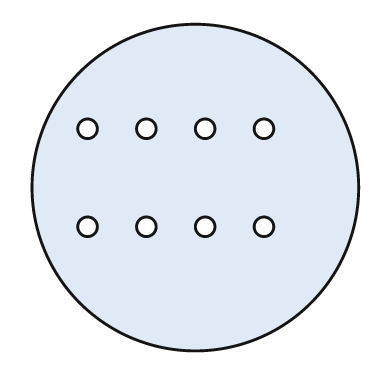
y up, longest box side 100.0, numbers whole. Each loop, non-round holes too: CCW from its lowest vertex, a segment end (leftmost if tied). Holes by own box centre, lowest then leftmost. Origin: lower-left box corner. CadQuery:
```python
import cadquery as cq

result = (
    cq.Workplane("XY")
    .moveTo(50.0, 50.0)
    .circle(50.0)
    .moveTo(17.0, 38.0)
    .circle(3.0)
    .moveTo(35.0, 38.0)
    .circle(3.0)
    .moveTo(53.0, 38.0)
    .circle(3.0)
    .moveTo(71.0, 38.0)
    .circle(3.0)
    .moveTo(17.0, 68.0)
    .circle(3.0)
    .moveTo(35.0, 68.0)
    .circle(3.0)
    .moveTo(53.0, 68.0)
    .circle(3.0)
    .moveTo(71.0, 68.0)
    .circle(3.0)
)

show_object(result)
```